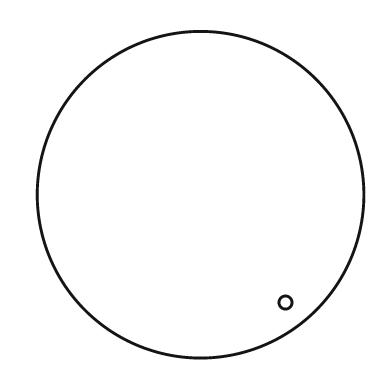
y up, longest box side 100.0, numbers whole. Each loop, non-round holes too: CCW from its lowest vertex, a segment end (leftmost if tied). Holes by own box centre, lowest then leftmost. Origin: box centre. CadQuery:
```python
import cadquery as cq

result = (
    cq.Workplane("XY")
    .moveTo(0.0, 0.0)
    .circle(50.0)
    .moveTo(26.0, -33.0)
    .circle(2.0)
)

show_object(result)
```